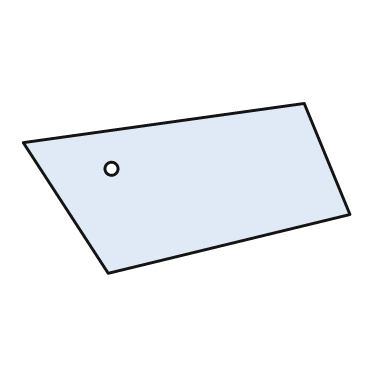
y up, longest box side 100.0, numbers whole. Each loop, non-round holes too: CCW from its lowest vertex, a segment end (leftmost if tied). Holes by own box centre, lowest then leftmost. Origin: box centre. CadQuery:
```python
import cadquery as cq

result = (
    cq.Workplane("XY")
    .moveTo(-24.0, -26.0)
    .lineTo(50.0, -8.0)
    .lineTo(36.0, 26.0)
    .lineTo(-50.0, 14.0)
    .close()
    .moveTo(-23.0, 6.0)
    .circle(2.0)
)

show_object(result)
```